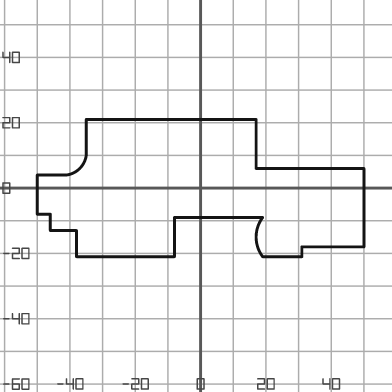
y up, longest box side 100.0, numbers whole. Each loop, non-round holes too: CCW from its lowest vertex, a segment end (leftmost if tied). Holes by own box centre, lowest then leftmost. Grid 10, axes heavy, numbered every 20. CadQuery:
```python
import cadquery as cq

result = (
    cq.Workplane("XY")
    .moveTo(-38.0, -21.0)
    .lineTo(-8.0, -21.0)
    .lineTo(-8.0, -9.0)
    .lineTo(19.0, -9.0)
    .threePointArc((17.0, -15.0), (19.0, -21.0))
    .lineTo(31.0, -21.0)
    .lineTo(31.0, -18.0)
    .lineTo(50.0, -18.0)
    .lineTo(50.0, 6.0)
    .lineTo(17.0, 6.0)
    .lineTo(17.0, 21.0)
    .lineTo(-35.0, 21.0)
    .lineTo(-35.0, 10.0)
    .threePointArc((-37.0, 6.0), (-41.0, 4.0))
    .lineTo(-50.0, 4.0)
    .lineTo(-50.0, -8.0)
    .lineTo(-46.0, -8.0)
    .lineTo(-46.0, -13.0)
    .lineTo(-38.0, -13.0)
    .close()
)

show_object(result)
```